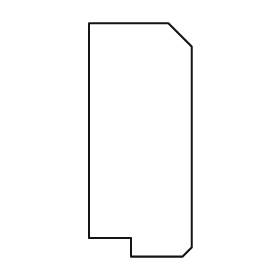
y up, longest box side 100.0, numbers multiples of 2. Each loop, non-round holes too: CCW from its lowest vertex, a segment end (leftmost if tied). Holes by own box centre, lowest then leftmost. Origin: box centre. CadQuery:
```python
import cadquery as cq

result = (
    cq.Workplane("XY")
    .moveTo(-4.0, -50.0)
    .lineTo(18.0, -50.0)
    .lineTo(22.0, -46.0)
    .lineTo(22.0, 40.0)
    .lineTo(12.0, 50.0)
    .lineTo(-22.0, 50.0)
    .lineTo(-22.0, -42.0)
    .lineTo(-4.0, -42.0)
    .close()
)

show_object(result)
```